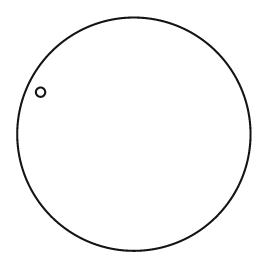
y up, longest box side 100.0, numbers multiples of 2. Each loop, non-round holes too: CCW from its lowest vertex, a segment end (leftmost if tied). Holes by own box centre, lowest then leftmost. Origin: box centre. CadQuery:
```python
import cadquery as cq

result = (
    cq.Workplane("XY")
    .moveTo(0.0, 0.0)
    .circle(50.0)
    .moveTo(-40.0, 18.0)
    .circle(2.0)
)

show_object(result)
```